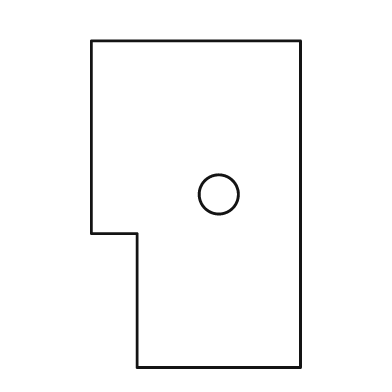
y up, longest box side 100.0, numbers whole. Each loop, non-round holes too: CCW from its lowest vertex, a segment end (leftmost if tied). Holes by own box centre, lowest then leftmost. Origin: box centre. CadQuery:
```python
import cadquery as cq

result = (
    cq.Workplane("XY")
    .moveTo(-18.0, -50.0)
    .lineTo(32.0, -50.0)
    .lineTo(32.0, 50.0)
    .lineTo(-32.0, 50.0)
    .lineTo(-32.0, -9.0)
    .lineTo(-18.0, -9.0)
    .close()
    .moveTo(7.0, 3.0)
    .circle(6.0)
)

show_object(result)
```